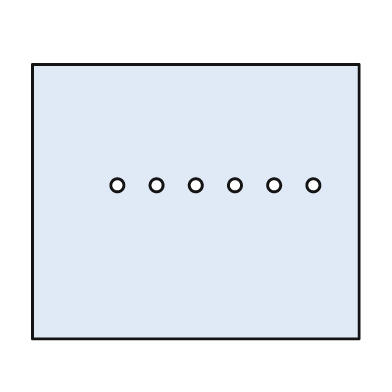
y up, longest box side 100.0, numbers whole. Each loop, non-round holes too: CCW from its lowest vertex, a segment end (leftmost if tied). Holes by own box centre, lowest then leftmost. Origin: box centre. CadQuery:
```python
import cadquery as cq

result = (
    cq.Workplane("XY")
    .moveTo(-50.0, -42.0)
    .lineTo(50.0, -42.0)
    .lineTo(50.0, 42.0)
    .lineTo(-50.0, 42.0)
    .close()
    .moveTo(-24.0, 5.0)
    .circle(2.0)
    .moveTo(-12.0, 5.0)
    .circle(2.0)
    .moveTo(0.0, 5.0)
    .circle(2.0)
    .moveTo(12.0, 5.0)
    .circle(2.0)
    .moveTo(24.0, 5.0)
    .circle(2.0)
    .moveTo(36.0, 5.0)
    .circle(2.0)
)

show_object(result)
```